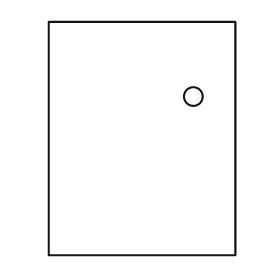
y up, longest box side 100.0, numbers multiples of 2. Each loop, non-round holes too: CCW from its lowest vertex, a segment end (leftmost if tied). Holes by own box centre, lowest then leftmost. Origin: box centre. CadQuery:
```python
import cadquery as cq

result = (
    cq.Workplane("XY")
    .moveTo(-40.0, -50.0)
    .lineTo(40.0, -50.0)
    .lineTo(40.0, 50.0)
    .lineTo(-40.0, 50.0)
    .close()
    .moveTo(22.0, 18.0)
    .circle(4.0)
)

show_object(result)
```